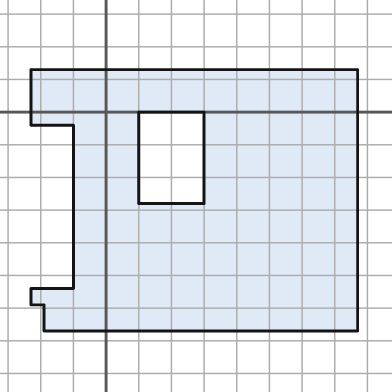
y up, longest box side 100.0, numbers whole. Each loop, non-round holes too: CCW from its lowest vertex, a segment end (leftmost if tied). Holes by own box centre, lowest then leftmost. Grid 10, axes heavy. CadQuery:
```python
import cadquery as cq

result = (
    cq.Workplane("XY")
    .moveTo(-19.0, -67.0)
    .lineTo(77.0, -67.0)
    .lineTo(77.0, 13.0)
    .lineTo(-23.0, 13.0)
    .lineTo(-23.0, -4.0)
    .lineTo(-10.0, -4.0)
    .lineTo(-10.0, -54.0)
    .lineTo(-23.0, -54.0)
    .lineTo(-23.0, -59.0)
    .lineTo(-19.0, -59.0)
    .close()
    .moveTo(10.0, -28.0)
    .lineTo(30.0, -28.0)
    .lineTo(30.0, 0.0)
    .lineTo(10.0, 0.0)
    .close()
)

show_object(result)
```